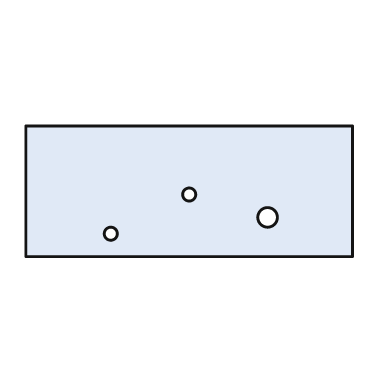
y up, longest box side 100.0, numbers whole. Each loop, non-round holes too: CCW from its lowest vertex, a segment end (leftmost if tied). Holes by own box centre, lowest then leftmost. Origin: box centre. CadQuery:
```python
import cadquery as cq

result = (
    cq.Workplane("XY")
    .moveTo(-50.0, -20.0)
    .lineTo(50.0, -20.0)
    .lineTo(50.0, 20.0)
    .lineTo(-50.0, 20.0)
    .close()
    .moveTo(-24.0, -13.0)
    .circle(2.0)
    .moveTo(24.0, -8.0)
    .circle(3.0)
    .moveTo(0.0, -1.0)
    .circle(2.0)
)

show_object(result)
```